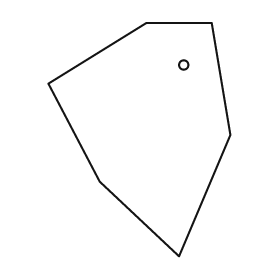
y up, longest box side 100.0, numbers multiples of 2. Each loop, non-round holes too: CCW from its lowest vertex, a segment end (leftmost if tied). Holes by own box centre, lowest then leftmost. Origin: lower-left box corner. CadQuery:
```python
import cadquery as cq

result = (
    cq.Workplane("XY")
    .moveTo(56.0, 0.0)
    .lineTo(78.0, 52.0)
    .lineTo(70.0, 100.0)
    .lineTo(42.0, 100.0)
    .lineTo(0.0, 74.0)
    .lineTo(22.0, 32.0)
    .close()
    .moveTo(58.0, 82.0)
    .circle(2.0)
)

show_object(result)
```